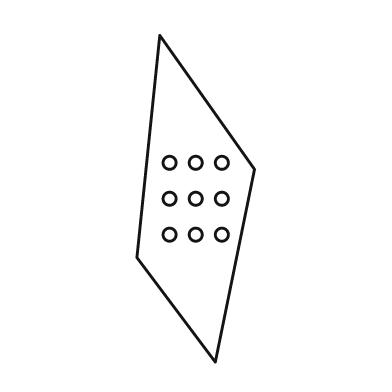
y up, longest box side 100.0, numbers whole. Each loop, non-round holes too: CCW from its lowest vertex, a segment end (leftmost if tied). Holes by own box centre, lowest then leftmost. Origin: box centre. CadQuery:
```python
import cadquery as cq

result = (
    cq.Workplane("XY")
    .moveTo(6.0, -50.0)
    .lineTo(18.0, 9.0)
    .lineTo(-11.0, 50.0)
    .lineTo(-18.0, -18.0)
    .close()
    .moveTo(-8.0, -11.0)
    .circle(2.0)
    .moveTo(0.0, -11.0)
    .circle(2.0)
    .moveTo(8.0, -11.0)
    .circle(2.0)
    .moveTo(-8.0, 0.0)
    .circle(2.0)
    .moveTo(0.0, 0.0)
    .circle(2.0)
    .moveTo(8.0, 0.0)
    .circle(2.0)
    .moveTo(-8.0, 11.0)
    .circle(2.0)
    .moveTo(0.0, 11.0)
    .circle(2.0)
    .moveTo(8.0, 11.0)
    .circle(2.0)
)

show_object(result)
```